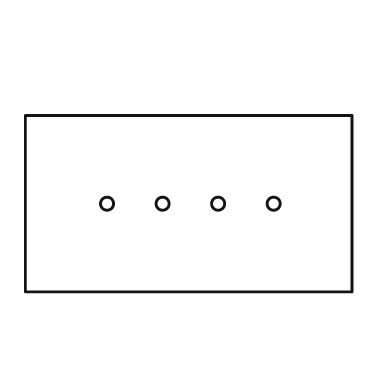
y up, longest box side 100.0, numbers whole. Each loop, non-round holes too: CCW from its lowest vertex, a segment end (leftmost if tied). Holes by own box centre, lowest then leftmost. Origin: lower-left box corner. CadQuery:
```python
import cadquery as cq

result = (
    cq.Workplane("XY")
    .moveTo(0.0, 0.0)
    .lineTo(100.0, 0.0)
    .lineTo(100.0, 54.0)
    .lineTo(0.0, 54.0)
    .close()
    .moveTo(25.0, 27.0)
    .circle(2.0)
    .moveTo(42.0, 27.0)
    .circle(2.0)
    .moveTo(59.0, 27.0)
    .circle(2.0)
    .moveTo(76.0, 27.0)
    .circle(2.0)
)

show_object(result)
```